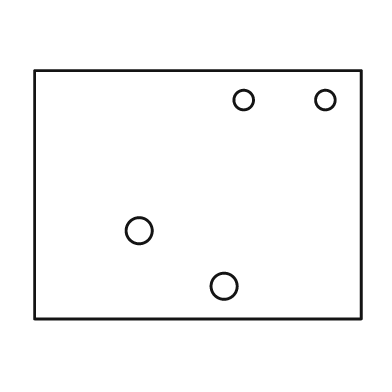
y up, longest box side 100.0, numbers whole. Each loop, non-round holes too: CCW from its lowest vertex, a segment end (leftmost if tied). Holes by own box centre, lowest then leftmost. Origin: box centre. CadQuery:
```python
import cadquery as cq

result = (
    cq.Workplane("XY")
    .moveTo(-50.0, -38.0)
    .lineTo(50.0, -38.0)
    .lineTo(50.0, 38.0)
    .lineTo(-50.0, 38.0)
    .close()
    .moveTo(8.0, -28.0)
    .circle(4.0)
    .moveTo(-18.0, -11.0)
    .circle(4.0)
    .moveTo(14.0, 29.0)
    .circle(3.0)
    .moveTo(39.0, 29.0)
    .circle(3.0)
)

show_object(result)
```